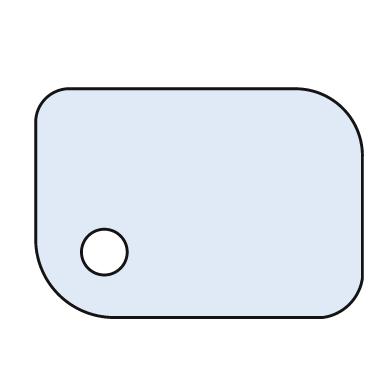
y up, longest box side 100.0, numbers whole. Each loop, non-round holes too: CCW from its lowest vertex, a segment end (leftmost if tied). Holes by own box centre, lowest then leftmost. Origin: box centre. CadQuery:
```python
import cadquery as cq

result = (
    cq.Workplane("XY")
    .moveTo(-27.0, -35.0)
    .lineTo(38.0, -35.0)
    .threePointArc((46.0, -31.0), (50.0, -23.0))
    .lineTo(50.0, 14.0)
    .threePointArc((44.0, 29.0), (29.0, 35.0))
    .lineTo(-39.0, 35.0)
    .threePointArc((-47.0, 32.0), (-50.0, 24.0))
    .lineTo(-50.0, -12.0)
    .threePointArc((-43.0, -28.0), (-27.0, -35.0))
    .close()
    .moveTo(-29.0, -15.0)
    .circle(7.0)
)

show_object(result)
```